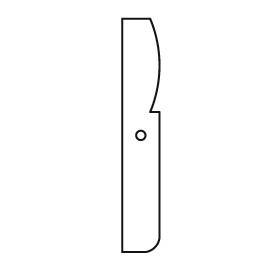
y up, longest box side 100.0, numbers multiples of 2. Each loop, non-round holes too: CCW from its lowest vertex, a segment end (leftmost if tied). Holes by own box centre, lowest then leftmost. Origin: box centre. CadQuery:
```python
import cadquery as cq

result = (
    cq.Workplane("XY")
    .moveTo(-8.0, -50.0)
    .lineTo(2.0, -50.0)
    .threePointArc((6.0, -48.0), (8.0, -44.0))
    .lineTo(8.0, 10.0)
    .lineTo(4.0, 10.0)
    .threePointArc((8.0, 30.0), (4.0, 50.0))
    .lineTo(-8.0, 50.0)
    .close()
    .moveTo(0.0, 0.0)
    .circle(2.0)
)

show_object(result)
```